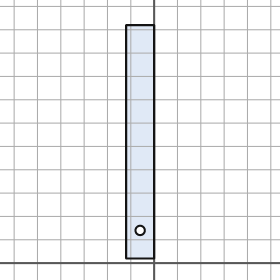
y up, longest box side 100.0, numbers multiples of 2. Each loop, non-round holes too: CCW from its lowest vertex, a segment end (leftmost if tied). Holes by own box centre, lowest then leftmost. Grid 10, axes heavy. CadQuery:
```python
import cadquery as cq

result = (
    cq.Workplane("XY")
    .moveTo(-12.0, 2.0)
    .lineTo(0.0, 2.0)
    .lineTo(0.0, 102.0)
    .lineTo(-12.0, 102.0)
    .close()
    .moveTo(-6.0, 14.0)
    .circle(2.0)
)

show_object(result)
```